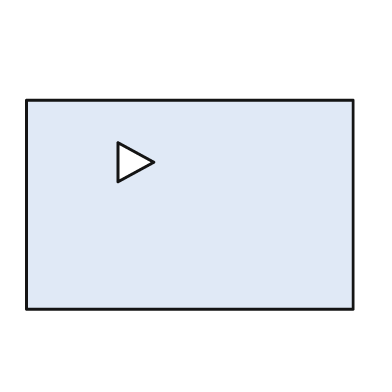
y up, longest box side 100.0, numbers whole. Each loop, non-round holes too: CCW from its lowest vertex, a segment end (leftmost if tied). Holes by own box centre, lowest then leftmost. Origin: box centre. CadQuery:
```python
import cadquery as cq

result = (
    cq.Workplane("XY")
    .moveTo(-50.0, -32.0)
    .lineTo(50.0, -32.0)
    .lineTo(50.0, 32.0)
    .lineTo(-50.0, 32.0)
    .close()
    .moveTo(-22.0, 7.0)
    .lineTo(-11.0, 13.0)
    .lineTo(-22.0, 19.0)
    .close()
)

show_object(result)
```